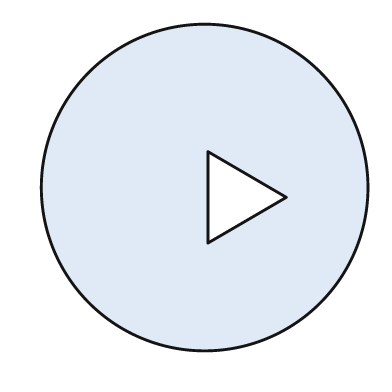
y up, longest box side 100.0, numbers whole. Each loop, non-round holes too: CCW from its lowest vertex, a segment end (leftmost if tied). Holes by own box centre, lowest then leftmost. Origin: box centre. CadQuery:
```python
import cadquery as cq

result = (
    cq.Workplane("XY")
    .moveTo(0.0, 0.0)
    .circle(50.0)
    .moveTo(1.0, -17.0)
    .lineTo(25.0, -3.0)
    .lineTo(1.0, 11.0)
    .close()
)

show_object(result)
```